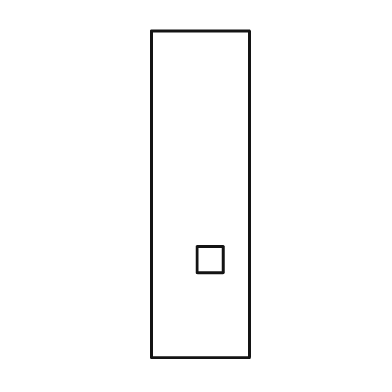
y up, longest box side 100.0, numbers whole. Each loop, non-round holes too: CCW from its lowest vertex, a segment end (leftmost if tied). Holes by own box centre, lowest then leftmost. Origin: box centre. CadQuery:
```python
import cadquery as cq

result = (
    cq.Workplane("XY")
    .moveTo(-15.0, -50.0)
    .lineTo(15.0, -50.0)
    .lineTo(15.0, 50.0)
    .lineTo(-15.0, 50.0)
    .close()
    .moveTo(-1.0, -24.0)
    .lineTo(7.0, -24.0)
    .lineTo(7.0, -16.0)
    .lineTo(-1.0, -16.0)
    .close()
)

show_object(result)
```